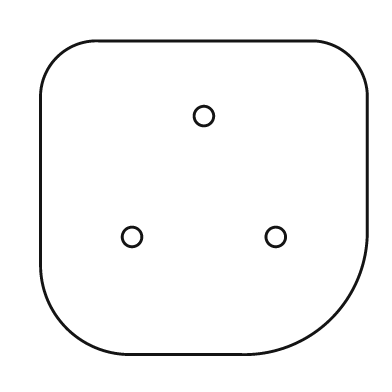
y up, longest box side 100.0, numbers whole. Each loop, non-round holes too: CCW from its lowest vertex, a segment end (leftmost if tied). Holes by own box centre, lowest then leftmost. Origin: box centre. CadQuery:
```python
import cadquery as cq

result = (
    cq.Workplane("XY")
    .moveTo(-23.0, -48.0)
    .lineTo(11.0, -48.0)
    .threePointArc((39.0, -37.0), (50.0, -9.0))
    .lineTo(50.0, 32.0)
    .threePointArc((45.0, 43.0), (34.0, 48.0))
    .lineTo(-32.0, 48.0)
    .threePointArc((-45.0, 43.0), (-50.0, 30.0))
    .lineTo(-50.0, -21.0)
    .threePointArc((-42.0, -40.0), (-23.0, -48.0))
    .close()
    .moveTo(-22.0, -12.0)
    .circle(3.0)
    .moveTo(22.0, -12.0)
    .circle(3.0)
    .moveTo(0.0, 25.0)
    .circle(3.0)
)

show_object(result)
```